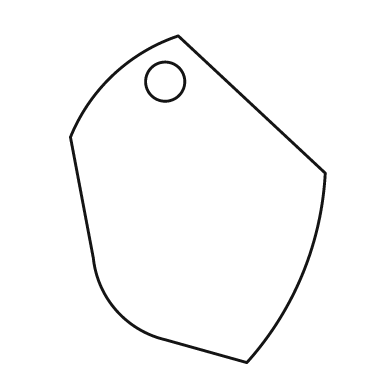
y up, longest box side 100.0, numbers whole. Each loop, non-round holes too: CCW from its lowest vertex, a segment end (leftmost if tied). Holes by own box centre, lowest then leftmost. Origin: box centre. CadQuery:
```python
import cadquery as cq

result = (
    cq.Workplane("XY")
    .moveTo(15.0, -50.0)
    .threePointArc((32.0, -23.0), (39.0, 8.0))
    .lineTo(-6.0, 50.0)
    .threePointArc((-26.0, 38.0), (-39.0, 19.0))
    .lineTo(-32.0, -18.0)
    .threePointArc((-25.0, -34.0), (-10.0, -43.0))
    .close()
    .moveTo(-10.0, 36.0)
    .circle(6.0)
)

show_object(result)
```